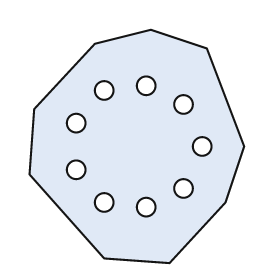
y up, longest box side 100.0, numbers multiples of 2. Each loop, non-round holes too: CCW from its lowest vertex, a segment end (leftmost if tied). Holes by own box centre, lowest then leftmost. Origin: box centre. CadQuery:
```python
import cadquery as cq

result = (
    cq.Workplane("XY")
    .moveTo(14.0, -50.0)
    .lineTo(38.0, -24.0)
    .lineTo(46.0, 0.0)
    .lineTo(30.0, 42.0)
    .lineTo(6.0, 50.0)
    .lineTo(-18.0, 44.0)
    .lineTo(-44.0, 16.0)
    .lineTo(-46.0, -12.0)
    .lineTo(-14.0, -48.0)
    .close()
    .moveTo(4.0, -26.0)
    .circle(4.0)
    .moveTo(-14.0, -24.0)
    .circle(4.0)
    .moveTo(20.0, -18.0)
    .circle(4.0)
    .moveTo(-26.0, -10.0)
    .circle(4.0)
    .moveTo(28.0, 0.0)
    .circle(4.0)
    .moveTo(-26.0, 10.0)
    .circle(4.0)
    .moveTo(20.0, 18.0)
    .circle(4.0)
    .moveTo(-14.0, 24.0)
    .circle(4.0)
    .moveTo(4.0, 26.0)
    .circle(4.0)
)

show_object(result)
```